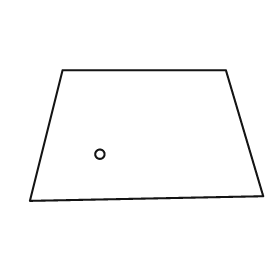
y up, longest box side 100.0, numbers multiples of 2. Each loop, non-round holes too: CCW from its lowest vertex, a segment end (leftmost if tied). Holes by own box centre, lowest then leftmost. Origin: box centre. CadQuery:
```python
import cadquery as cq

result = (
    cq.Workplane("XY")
    .moveTo(-50.0, -28.0)
    .lineTo(50.0, -26.0)
    .lineTo(34.0, 28.0)
    .lineTo(-36.0, 28.0)
    .close()
    .moveTo(-20.0, -8.0)
    .circle(2.0)
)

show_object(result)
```